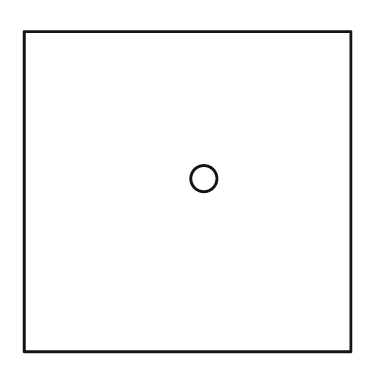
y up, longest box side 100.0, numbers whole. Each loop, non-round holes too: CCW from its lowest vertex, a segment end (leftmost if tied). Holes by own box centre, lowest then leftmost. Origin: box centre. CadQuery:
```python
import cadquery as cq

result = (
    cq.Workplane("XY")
    .moveTo(-50.0, -49.0)
    .lineTo(50.0, -49.0)
    .lineTo(50.0, 49.0)
    .lineTo(-50.0, 49.0)
    .close()
    .moveTo(5.0, 4.0)
    .circle(4.0)
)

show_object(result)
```